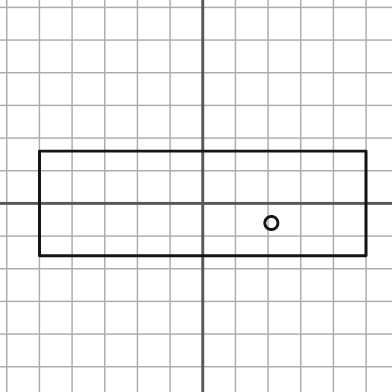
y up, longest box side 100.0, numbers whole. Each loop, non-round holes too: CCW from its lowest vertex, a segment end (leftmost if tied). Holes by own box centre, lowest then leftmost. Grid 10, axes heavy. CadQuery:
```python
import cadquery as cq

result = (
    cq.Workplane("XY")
    .moveTo(-50.0, -16.0)
    .lineTo(50.0, -16.0)
    .lineTo(50.0, 16.0)
    .lineTo(-50.0, 16.0)
    .close()
    .moveTo(21.0, -6.0)
    .circle(2.0)
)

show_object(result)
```